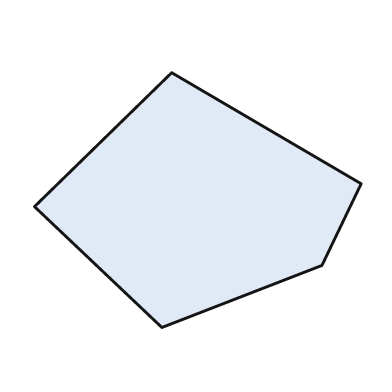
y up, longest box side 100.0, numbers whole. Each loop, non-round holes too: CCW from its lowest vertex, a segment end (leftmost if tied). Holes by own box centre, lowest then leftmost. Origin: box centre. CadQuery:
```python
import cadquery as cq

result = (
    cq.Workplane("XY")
    .moveTo(-11.0, -39.0)
    .lineTo(38.0, -20.0)
    .lineTo(50.0, 5.0)
    .lineTo(-8.0, 39.0)
    .lineTo(-50.0, -2.0)
    .close()
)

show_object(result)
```